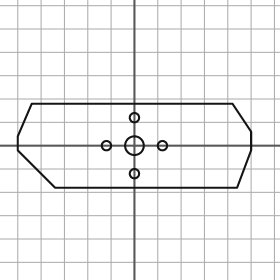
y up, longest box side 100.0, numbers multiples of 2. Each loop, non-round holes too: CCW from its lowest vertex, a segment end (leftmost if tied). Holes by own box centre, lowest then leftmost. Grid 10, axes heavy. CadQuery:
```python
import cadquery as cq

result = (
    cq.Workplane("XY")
    .moveTo(-34.0, -18.0)
    .lineTo(44.0, -18.0)
    .lineTo(50.0, -2.0)
    .lineTo(50.0, 6.0)
    .lineTo(42.0, 18.0)
    .lineTo(-44.0, 18.0)
    .lineTo(-50.0, 4.0)
    .lineTo(-50.0, -2.0)
    .close()
    .moveTo(0.0, -12.0)
    .circle(2.0)
    .moveTo(-12.0, 0.0)
    .circle(2.0)
    .moveTo(0.0, 0.0)
    .circle(4.0)
    .moveTo(12.0, 0.0)
    .circle(2.0)
    .moveTo(0.0, 12.0)
    .circle(2.0)
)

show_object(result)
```